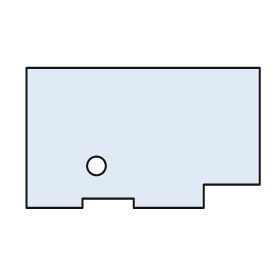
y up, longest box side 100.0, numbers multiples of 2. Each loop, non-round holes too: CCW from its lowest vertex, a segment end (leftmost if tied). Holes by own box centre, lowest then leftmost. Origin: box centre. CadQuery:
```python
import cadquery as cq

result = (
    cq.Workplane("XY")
    .moveTo(-50.0, -30.0)
    .lineTo(-26.0, -30.0)
    .lineTo(-26.0, -26.0)
    .lineTo(-4.0, -26.0)
    .lineTo(-4.0, -30.0)
    .lineTo(26.0, -30.0)
    .lineTo(26.0, -20.0)
    .lineTo(50.0, -20.0)
    .lineTo(50.0, 30.0)
    .lineTo(-50.0, 30.0)
    .close()
    .moveTo(-20.0, -12.0)
    .circle(4.0)
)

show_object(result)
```